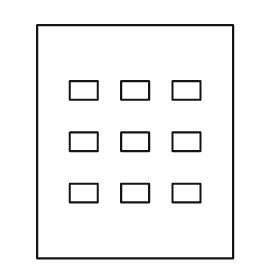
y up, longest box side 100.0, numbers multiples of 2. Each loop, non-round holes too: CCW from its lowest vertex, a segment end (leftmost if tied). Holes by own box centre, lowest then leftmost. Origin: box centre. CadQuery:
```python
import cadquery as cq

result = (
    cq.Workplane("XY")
    .moveTo(-42.0, -50.0)
    .lineTo(42.0, -50.0)
    .lineTo(42.0, 50.0)
    .lineTo(-42.0, 50.0)
    .close()
    .moveTo(-28.0, -26.0)
    .lineTo(-16.0, -26.0)
    .lineTo(-16.0, -18.0)
    .lineTo(-28.0, -18.0)
    .close()
    .moveTo(-6.0, -26.0)
    .lineTo(6.0, -26.0)
    .lineTo(6.0, -18.0)
    .lineTo(-6.0, -18.0)
    .close()
    .moveTo(16.0, -26.0)
    .lineTo(28.0, -26.0)
    .lineTo(28.0, -18.0)
    .lineTo(16.0, -18.0)
    .close()
    .moveTo(-28.0, -4.0)
    .lineTo(-16.0, -4.0)
    .lineTo(-16.0, 4.0)
    .lineTo(-28.0, 4.0)
    .close()
    .moveTo(-6.0, -4.0)
    .lineTo(6.0, -4.0)
    .lineTo(6.0, 4.0)
    .lineTo(-6.0, 4.0)
    .close()
    .moveTo(16.0, -4.0)
    .lineTo(28.0, -4.0)
    .lineTo(28.0, 4.0)
    .lineTo(16.0, 4.0)
    .close()
    .moveTo(-28.0, 18.0)
    .lineTo(-16.0, 18.0)
    .lineTo(-16.0, 26.0)
    .lineTo(-28.0, 26.0)
    .close()
    .moveTo(-6.0, 18.0)
    .lineTo(6.0, 18.0)
    .lineTo(6.0, 26.0)
    .lineTo(-6.0, 26.0)
    .close()
    .moveTo(16.0, 18.0)
    .lineTo(28.0, 18.0)
    .lineTo(28.0, 26.0)
    .lineTo(16.0, 26.0)
    .close()
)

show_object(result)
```